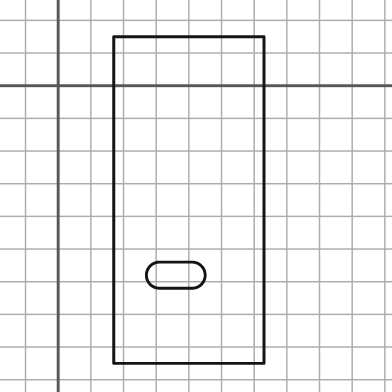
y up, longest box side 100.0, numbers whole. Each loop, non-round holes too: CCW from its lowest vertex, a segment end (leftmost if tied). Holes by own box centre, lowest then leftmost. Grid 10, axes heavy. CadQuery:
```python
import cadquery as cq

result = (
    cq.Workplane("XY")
    .moveTo(17.0, -85.0)
    .lineTo(63.0, -85.0)
    .lineTo(63.0, 15.0)
    .lineTo(17.0, 15.0)
    .close()
    .moveTo(31.0, -62.0)
    .lineTo(41.0, -62.0)
    .threePointArc((45.0, -58.0), (41.0, -54.0))
    .lineTo(31.0, -54.0)
    .threePointArc((27.0, -58.0), (31.0, -62.0))
    .close()
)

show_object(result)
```